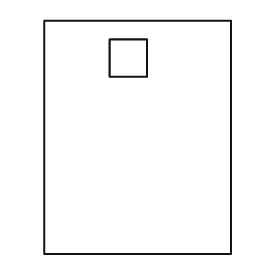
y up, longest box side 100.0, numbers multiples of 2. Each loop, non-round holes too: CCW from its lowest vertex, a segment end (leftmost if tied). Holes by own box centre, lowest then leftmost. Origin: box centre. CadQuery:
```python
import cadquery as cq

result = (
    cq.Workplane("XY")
    .moveTo(-40.0, -50.0)
    .lineTo(40.0, -50.0)
    .lineTo(40.0, 50.0)
    .lineTo(-40.0, 50.0)
    .close()
    .moveTo(-12.0, 26.0)
    .lineTo(4.0, 26.0)
    .lineTo(4.0, 42.0)
    .lineTo(-12.0, 42.0)
    .close()
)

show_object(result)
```